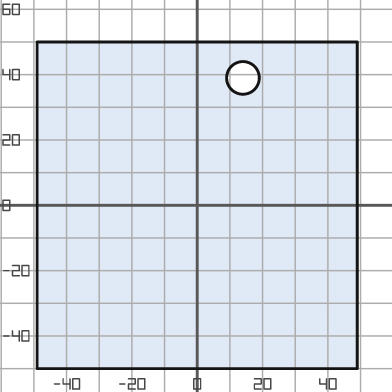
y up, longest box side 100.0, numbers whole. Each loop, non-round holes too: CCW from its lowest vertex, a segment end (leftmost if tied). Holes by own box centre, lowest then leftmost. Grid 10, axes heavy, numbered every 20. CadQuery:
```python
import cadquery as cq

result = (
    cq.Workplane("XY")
    .moveTo(-49.0, -50.0)
    .lineTo(49.0, -50.0)
    .lineTo(49.0, 50.0)
    .lineTo(-49.0, 50.0)
    .close()
    .moveTo(14.0, 39.0)
    .circle(5.0)
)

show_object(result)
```